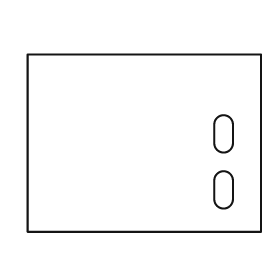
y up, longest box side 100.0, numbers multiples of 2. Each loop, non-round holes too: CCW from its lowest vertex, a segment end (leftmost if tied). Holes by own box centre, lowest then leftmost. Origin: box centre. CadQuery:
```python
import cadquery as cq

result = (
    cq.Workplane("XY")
    .moveTo(-50.0, -38.0)
    .lineTo(50.0, -38.0)
    .lineTo(50.0, 38.0)
    .lineTo(-50.0, 38.0)
    .close()
    .moveTo(30.0, -24.0)
    .threePointArc((34.0, -28.0), (38.0, -24.0))
    .lineTo(38.0, -16.0)
    .threePointArc((34.0, -12.0), (30.0, -16.0))
    .close()
    .moveTo(30.0, 0.0)
    .threePointArc((34.0, -4.0), (38.0, 0.0))
    .lineTo(38.0, 8.0)
    .threePointArc((34.0, 12.0), (30.0, 8.0))
    .close()
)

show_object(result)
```